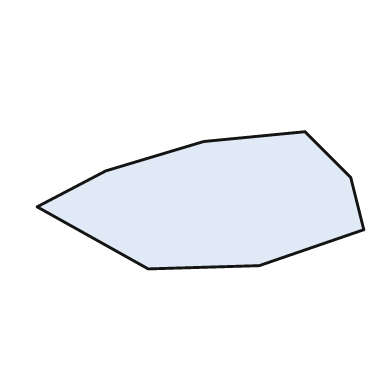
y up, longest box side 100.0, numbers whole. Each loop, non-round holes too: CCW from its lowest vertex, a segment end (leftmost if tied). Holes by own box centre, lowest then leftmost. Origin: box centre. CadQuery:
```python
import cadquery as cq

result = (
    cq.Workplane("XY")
    .moveTo(-16.0, -21.0)
    .lineTo(18.0, -20.0)
    .lineTo(50.0, -9.0)
    .lineTo(46.0, 7.0)
    .lineTo(32.0, 21.0)
    .lineTo(1.0, 18.0)
    .lineTo(-29.0, 9.0)
    .lineTo(-50.0, -2.0)
    .close()
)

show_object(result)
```